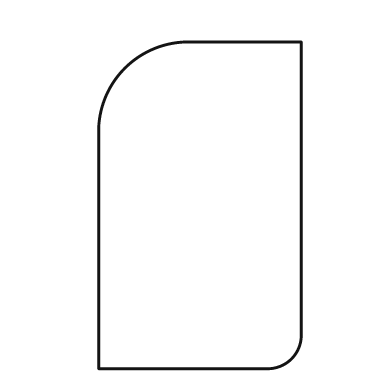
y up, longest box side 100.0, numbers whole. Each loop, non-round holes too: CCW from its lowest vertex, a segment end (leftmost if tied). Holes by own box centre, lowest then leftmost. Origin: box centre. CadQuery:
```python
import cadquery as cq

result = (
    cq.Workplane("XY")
    .moveTo(-31.0, -50.0)
    .lineTo(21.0, -50.0)
    .threePointArc((28.0, -47.0), (31.0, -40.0))
    .lineTo(31.0, 50.0)
    .lineTo(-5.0, 50.0)
    .threePointArc((-23.0, 42.0), (-31.0, 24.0))
    .close()
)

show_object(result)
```